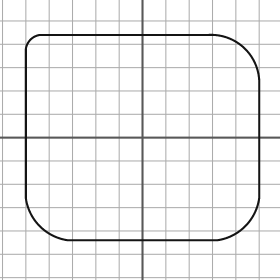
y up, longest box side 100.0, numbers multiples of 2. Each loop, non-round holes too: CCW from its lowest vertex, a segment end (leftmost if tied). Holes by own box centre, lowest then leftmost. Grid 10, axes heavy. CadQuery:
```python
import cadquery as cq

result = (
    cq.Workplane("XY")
    .moveTo(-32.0, -44.0)
    .lineTo(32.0, -44.0)
    .threePointArc((44.0, -38.0), (50.0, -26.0))
    .lineTo(50.0, 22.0)
    .threePointArc((44.0, 38.0), (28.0, 44.0))
    .lineTo(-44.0, 44.0)
    .threePointArc((-48.0, 42.0), (-50.0, 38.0))
    .lineTo(-50.0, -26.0)
    .threePointArc((-44.0, -38.0), (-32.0, -44.0))
    .close()
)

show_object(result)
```